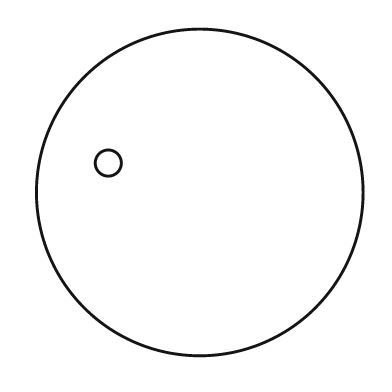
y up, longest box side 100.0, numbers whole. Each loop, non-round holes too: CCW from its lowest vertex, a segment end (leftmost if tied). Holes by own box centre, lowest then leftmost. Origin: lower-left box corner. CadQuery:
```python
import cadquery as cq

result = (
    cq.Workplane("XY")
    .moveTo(50.0, 50.0)
    .circle(50.0)
    .moveTo(22.0, 59.0)
    .circle(4.0)
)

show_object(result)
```